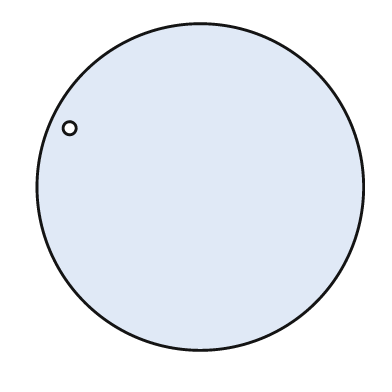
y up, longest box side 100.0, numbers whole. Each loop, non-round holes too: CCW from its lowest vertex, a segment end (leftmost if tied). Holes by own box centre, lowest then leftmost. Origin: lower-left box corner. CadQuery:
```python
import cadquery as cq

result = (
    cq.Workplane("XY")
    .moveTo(50.0, 50.0)
    .circle(50.0)
    .moveTo(10.0, 68.0)
    .circle(2.0)
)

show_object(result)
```